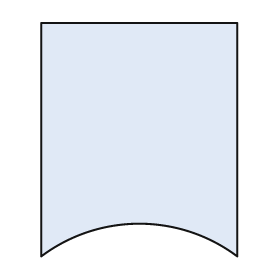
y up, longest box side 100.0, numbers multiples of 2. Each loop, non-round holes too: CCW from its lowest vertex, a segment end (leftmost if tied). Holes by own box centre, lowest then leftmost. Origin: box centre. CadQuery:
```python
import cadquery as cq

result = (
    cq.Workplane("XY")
    .moveTo(-42.0, -50.0)
    .threePointArc((0.0, -36.0), (42.0, -50.0))
    .lineTo(42.0, 50.0)
    .lineTo(-42.0, 50.0)
    .close()
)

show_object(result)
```